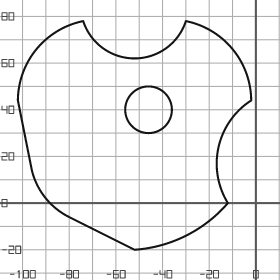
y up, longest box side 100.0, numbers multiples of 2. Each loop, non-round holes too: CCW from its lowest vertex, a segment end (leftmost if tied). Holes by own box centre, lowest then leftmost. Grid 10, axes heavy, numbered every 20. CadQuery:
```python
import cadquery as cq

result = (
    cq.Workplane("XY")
    .moveTo(-52.0, -20.0)
    .threePointArc((-30.0, -14.0), (-12.0, 0.0))
    .threePointArc((-16.0, 24.0), (-2.0, 44.0))
    .threePointArc((-10.0, 66.0), (-30.0, 78.0))
    .threePointArc((-52.0, 62.0), (-74.0, 78.0))
    .threePointArc((-94.0, 66.0), (-102.0, 44.0))
    .lineTo(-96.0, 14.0)
    .threePointArc((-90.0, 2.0), (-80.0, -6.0))
    .close()
    .moveTo(-46.0, 40.0)
    .circle(10.0)
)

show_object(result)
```